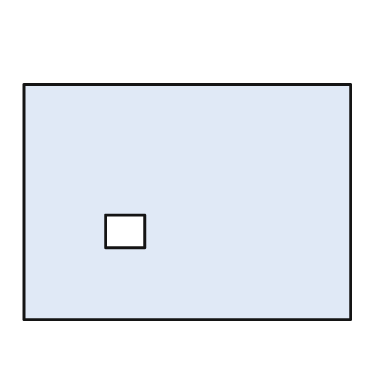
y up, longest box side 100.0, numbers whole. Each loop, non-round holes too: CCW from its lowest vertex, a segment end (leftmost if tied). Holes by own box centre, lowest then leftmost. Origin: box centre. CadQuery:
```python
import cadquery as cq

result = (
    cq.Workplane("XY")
    .moveTo(-50.0, -36.0)
    .lineTo(50.0, -36.0)
    .lineTo(50.0, 36.0)
    .lineTo(-50.0, 36.0)
    .close()
    .moveTo(-25.0, -14.0)
    .lineTo(-13.0, -14.0)
    .lineTo(-13.0, -4.0)
    .lineTo(-25.0, -4.0)
    .close()
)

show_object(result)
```